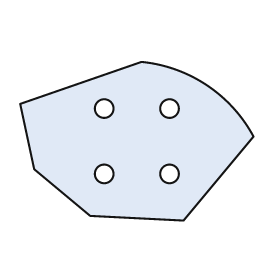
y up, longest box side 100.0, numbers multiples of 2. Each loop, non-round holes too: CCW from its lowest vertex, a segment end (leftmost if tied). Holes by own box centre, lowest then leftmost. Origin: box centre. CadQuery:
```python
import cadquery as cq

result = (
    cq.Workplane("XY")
    .moveTo(20.0, -34.0)
    .lineTo(50.0, 2.0)
    .threePointArc((30.0, 24.0), (2.0, 34.0))
    .lineTo(-50.0, 16.0)
    .lineTo(-44.0, -12.0)
    .lineTo(-20.0, -32.0)
    .close()
    .moveTo(-14.0, -14.0)
    .circle(4.0)
    .moveTo(14.0, -14.0)
    .circle(4.0)
    .moveTo(-14.0, 14.0)
    .circle(4.0)
    .moveTo(14.0, 14.0)
    .circle(4.0)
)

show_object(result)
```